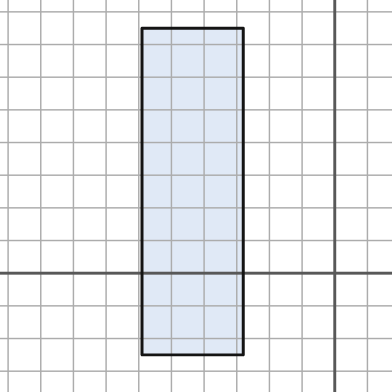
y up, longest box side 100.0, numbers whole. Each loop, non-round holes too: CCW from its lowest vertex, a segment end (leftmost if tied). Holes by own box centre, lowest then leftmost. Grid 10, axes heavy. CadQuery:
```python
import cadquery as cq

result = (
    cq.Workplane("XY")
    .moveTo(-59.0, -25.0)
    .lineTo(-28.0, -25.0)
    .lineTo(-28.0, 75.0)
    .lineTo(-59.0, 75.0)
    .close()
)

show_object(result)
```